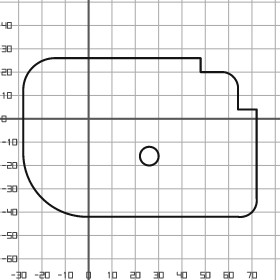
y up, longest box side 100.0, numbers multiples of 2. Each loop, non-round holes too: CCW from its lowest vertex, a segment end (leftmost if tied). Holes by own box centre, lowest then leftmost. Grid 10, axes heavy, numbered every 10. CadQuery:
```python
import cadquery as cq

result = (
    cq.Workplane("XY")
    .moveTo(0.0, -42.0)
    .lineTo(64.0, -42.0)
    .threePointArc((70.0, -40.0), (72.0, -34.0))
    .lineTo(72.0, 4.0)
    .lineTo(64.0, 4.0)
    .lineTo(64.0, 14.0)
    .threePointArc((62.0, 18.0), (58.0, 20.0))
    .lineTo(48.0, 20.0)
    .lineTo(48.0, 26.0)
    .lineTo(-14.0, 26.0)
    .threePointArc((-24.0, 22.0), (-28.0, 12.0))
    .lineTo(-28.0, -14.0)
    .threePointArc((-20.0, -34.0), (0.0, -42.0))
    .close()
    .moveTo(26.0, -16.0)
    .circle(4.0)
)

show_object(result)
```